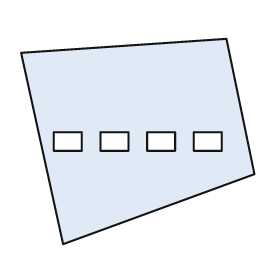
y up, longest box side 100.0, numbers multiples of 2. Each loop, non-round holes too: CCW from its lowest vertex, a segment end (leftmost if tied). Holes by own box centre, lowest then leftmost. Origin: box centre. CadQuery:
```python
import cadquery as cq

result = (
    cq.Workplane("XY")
    .moveTo(-32.0, -44.0)
    .lineTo(50.0, -14.0)
    .lineTo(38.0, 44.0)
    .lineTo(-50.0, 38.0)
    .close()
    .moveTo(-36.0, -4.0)
    .lineTo(-24.0, -4.0)
    .lineTo(-24.0, 4.0)
    .lineTo(-36.0, 4.0)
    .close()
    .moveTo(-16.0, -4.0)
    .lineTo(-4.0, -4.0)
    .lineTo(-4.0, 4.0)
    .lineTo(-16.0, 4.0)
    .close()
    .moveTo(4.0, -4.0)
    .lineTo(16.0, -4.0)
    .lineTo(16.0, 4.0)
    .lineTo(4.0, 4.0)
    .close()
    .moveTo(24.0, -4.0)
    .lineTo(36.0, -4.0)
    .lineTo(36.0, 4.0)
    .lineTo(24.0, 4.0)
    .close()
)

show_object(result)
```